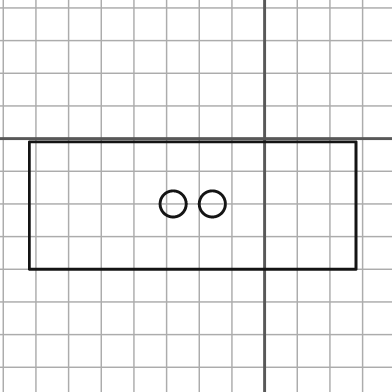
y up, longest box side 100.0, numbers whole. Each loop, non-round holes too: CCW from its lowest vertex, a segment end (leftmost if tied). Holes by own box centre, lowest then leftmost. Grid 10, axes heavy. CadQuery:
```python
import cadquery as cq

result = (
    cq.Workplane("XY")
    .moveTo(-72.0, -40.0)
    .lineTo(28.0, -40.0)
    .lineTo(28.0, -1.0)
    .lineTo(-72.0, -1.0)
    .close()
    .moveTo(-28.0, -20.0)
    .circle(4.0)
    .moveTo(-16.0, -20.0)
    .circle(4.0)
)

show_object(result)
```